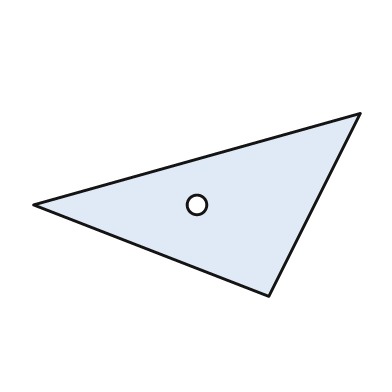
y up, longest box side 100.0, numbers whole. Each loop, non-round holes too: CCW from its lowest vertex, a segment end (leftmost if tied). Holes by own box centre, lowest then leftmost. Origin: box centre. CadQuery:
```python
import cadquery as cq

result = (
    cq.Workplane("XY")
    .moveTo(22.0, -28.0)
    .lineTo(50.0, 28.0)
    .lineTo(-50.0, 0.0)
    .close()
    .moveTo(0.0, 0.0)
    .circle(3.0)
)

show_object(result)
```